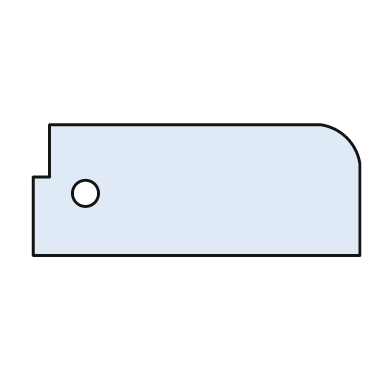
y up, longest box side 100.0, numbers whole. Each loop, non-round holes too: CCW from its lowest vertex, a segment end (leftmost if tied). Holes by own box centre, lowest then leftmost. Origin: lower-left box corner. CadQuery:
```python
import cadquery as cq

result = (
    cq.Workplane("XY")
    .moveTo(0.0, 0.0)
    .lineTo(100.0, 0.0)
    .lineTo(100.0, 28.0)
    .threePointArc((96.0, 36.0), (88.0, 40.0))
    .lineTo(5.0, 40.0)
    .lineTo(5.0, 24.0)
    .lineTo(0.0, 24.0)
    .close()
    .moveTo(16.0, 19.0)
    .circle(4.0)
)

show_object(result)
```